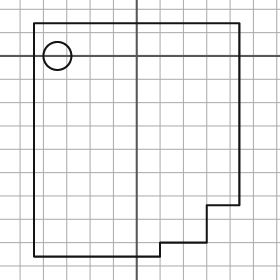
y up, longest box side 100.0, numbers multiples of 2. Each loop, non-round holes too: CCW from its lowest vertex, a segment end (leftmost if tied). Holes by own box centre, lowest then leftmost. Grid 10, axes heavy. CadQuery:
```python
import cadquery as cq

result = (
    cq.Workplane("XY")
    .moveTo(-44.0, -86.0)
    .lineTo(10.0, -86.0)
    .lineTo(10.0, -80.0)
    .lineTo(30.0, -80.0)
    .lineTo(30.0, -64.0)
    .lineTo(44.0, -64.0)
    .lineTo(44.0, 14.0)
    .lineTo(-44.0, 14.0)
    .close()
    .moveTo(-34.0, 0.0)
    .circle(6.0)
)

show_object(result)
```